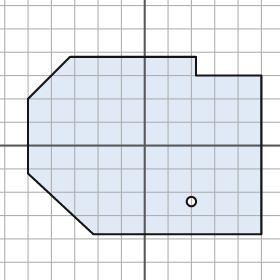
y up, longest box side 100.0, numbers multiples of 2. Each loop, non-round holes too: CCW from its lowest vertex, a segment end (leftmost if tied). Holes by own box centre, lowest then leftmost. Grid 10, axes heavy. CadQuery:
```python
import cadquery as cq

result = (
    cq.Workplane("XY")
    .moveTo(-22.0, -38.0)
    .lineTo(50.0, -38.0)
    .lineTo(50.0, 30.0)
    .lineTo(22.0, 30.0)
    .lineTo(22.0, 38.0)
    .lineTo(-32.0, 38.0)
    .lineTo(-50.0, 20.0)
    .lineTo(-50.0, -12.0)
    .close()
    .moveTo(20.0, -24.0)
    .circle(2.0)
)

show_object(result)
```